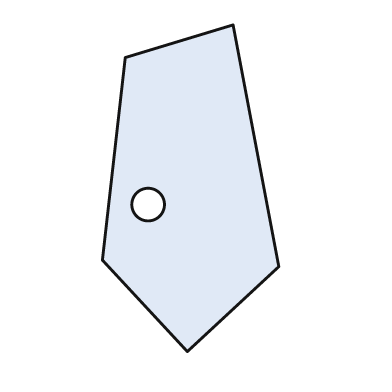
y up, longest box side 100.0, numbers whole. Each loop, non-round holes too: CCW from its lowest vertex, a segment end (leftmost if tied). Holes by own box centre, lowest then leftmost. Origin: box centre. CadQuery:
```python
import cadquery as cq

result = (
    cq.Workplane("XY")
    .moveTo(-1.0, -50.0)
    .lineTo(27.0, -24.0)
    .lineTo(13.0, 50.0)
    .lineTo(-20.0, 40.0)
    .lineTo(-27.0, -22.0)
    .close()
    .moveTo(-13.0, -5.0)
    .circle(5.0)
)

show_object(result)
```